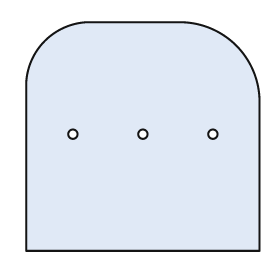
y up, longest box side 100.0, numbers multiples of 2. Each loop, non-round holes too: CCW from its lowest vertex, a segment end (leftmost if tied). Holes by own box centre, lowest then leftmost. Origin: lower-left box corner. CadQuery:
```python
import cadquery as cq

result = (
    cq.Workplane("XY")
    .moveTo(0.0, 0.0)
    .lineTo(100.0, 0.0)
    .lineTo(100.0, 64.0)
    .threePointArc((90.0, 88.0), (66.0, 98.0))
    .lineTo(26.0, 98.0)
    .threePointArc((8.0, 90.0), (0.0, 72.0))
    .close()
    .moveTo(20.0, 50.0)
    .circle(2.0)
    .moveTo(50.0, 50.0)
    .circle(2.0)
    .moveTo(80.0, 50.0)
    .circle(2.0)
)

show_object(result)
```